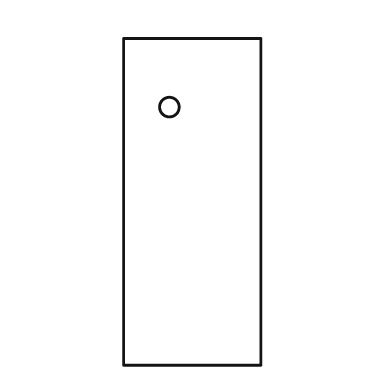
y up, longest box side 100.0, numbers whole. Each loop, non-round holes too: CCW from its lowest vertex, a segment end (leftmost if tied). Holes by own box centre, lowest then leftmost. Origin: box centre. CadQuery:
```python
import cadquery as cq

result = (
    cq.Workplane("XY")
    .moveTo(-21.0, -50.0)
    .lineTo(21.0, -50.0)
    .lineTo(21.0, 50.0)
    .lineTo(-21.0, 50.0)
    .close()
    .moveTo(-7.0, 29.0)
    .circle(3.0)
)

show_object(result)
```